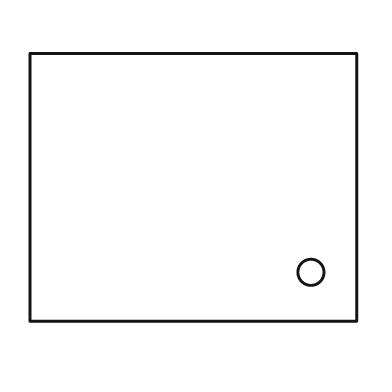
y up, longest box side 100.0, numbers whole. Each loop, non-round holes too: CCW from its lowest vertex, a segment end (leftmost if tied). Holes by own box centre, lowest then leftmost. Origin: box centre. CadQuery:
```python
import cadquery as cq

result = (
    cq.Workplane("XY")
    .moveTo(-50.0, -41.0)
    .lineTo(50.0, -41.0)
    .lineTo(50.0, 41.0)
    .lineTo(-50.0, 41.0)
    .close()
    .moveTo(36.0, -26.0)
    .circle(4.0)
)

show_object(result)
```